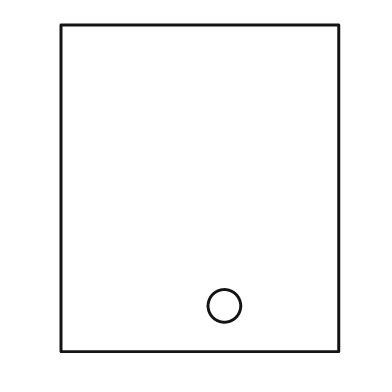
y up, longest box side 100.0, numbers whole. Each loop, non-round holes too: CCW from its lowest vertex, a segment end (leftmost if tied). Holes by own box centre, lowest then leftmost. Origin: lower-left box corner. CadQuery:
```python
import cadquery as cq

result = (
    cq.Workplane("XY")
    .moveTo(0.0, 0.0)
    .lineTo(85.0, 0.0)
    .lineTo(85.0, 100.0)
    .lineTo(0.0, 100.0)
    .close()
    .moveTo(50.0, 14.0)
    .circle(5.0)
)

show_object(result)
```